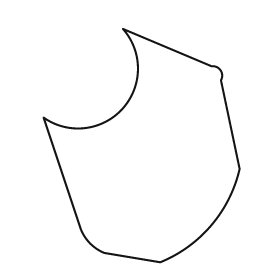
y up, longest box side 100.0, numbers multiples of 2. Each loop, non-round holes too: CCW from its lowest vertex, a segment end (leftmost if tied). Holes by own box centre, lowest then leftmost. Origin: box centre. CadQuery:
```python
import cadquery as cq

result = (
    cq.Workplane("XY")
    .moveTo(8.0, -50.0)
    .threePointArc((30.0, -34.0), (42.0, -10.0))
    .lineTo(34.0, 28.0)
    .threePointArc((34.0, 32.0), (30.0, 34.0))
    .lineTo(-8.0, 50.0)
    .threePointArc((-8.0, 16.0), (-42.0, 12.0))
    .lineTo(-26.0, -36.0)
    .threePointArc((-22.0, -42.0), (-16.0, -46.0))
    .close()
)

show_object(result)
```